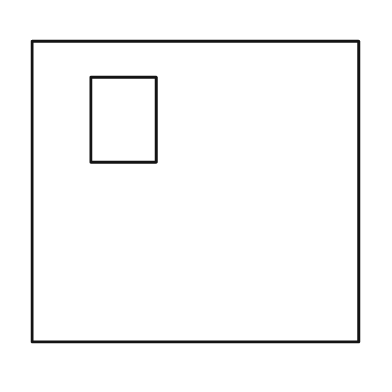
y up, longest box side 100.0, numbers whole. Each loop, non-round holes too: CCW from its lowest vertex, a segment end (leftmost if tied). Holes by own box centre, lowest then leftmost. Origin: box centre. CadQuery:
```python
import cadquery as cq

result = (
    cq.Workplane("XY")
    .moveTo(-50.0, -46.0)
    .lineTo(50.0, -46.0)
    .lineTo(50.0, 46.0)
    .lineTo(-50.0, 46.0)
    .close()
    .moveTo(-32.0, 9.0)
    .lineTo(-12.0, 9.0)
    .lineTo(-12.0, 35.0)
    .lineTo(-32.0, 35.0)
    .close()
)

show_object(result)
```